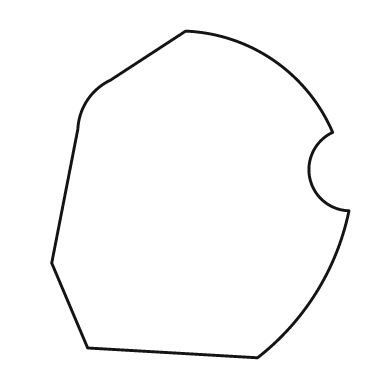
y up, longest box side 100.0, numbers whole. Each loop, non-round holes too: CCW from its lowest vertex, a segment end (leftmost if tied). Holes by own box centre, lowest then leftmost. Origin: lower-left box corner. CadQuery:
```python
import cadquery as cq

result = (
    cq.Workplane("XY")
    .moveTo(63.0, 0.0)
    .threePointArc((81.0, 20.0), (91.0, 45.0))
    .threePointArc((79.0, 55.0), (86.0, 69.0))
    .threePointArc((68.0, 91.0), (41.0, 100.0))
    .lineTo(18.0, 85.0)
    .threePointArc((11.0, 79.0), (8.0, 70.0))
    .lineTo(0.0, 29.0)
    .lineTo(11.0, 3.0)
    .close()
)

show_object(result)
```